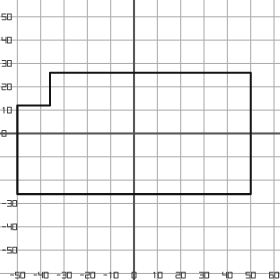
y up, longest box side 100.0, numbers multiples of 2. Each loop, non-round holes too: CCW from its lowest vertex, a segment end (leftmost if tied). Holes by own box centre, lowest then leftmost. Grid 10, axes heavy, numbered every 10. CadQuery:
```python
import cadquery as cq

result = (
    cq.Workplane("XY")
    .moveTo(-50.0, -26.0)
    .lineTo(50.0, -26.0)
    .lineTo(50.0, 26.0)
    .lineTo(-36.0, 26.0)
    .lineTo(-36.0, 12.0)
    .lineTo(-50.0, 12.0)
    .close()
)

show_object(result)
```